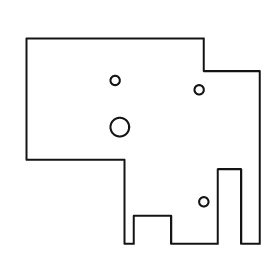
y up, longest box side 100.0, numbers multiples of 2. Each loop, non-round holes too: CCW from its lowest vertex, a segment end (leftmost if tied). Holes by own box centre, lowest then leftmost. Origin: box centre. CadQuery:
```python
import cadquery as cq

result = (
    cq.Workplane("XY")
    .moveTo(-8.0, -44.0)
    .lineTo(-4.0, -44.0)
    .lineTo(-4.0, -32.0)
    .lineTo(12.0, -32.0)
    .lineTo(12.0, -44.0)
    .lineTo(32.0, -44.0)
    .lineTo(32.0, -12.0)
    .lineTo(42.0, -12.0)
    .lineTo(42.0, -44.0)
    .lineTo(50.0, -44.0)
    .lineTo(50.0, 30.0)
    .lineTo(26.0, 30.0)
    .lineTo(26.0, 44.0)
    .lineTo(-50.0, 44.0)
    .lineTo(-50.0, -8.0)
    .lineTo(-8.0, -8.0)
    .close()
    .moveTo(26.0, -26.0)
    .circle(2.0)
    .moveTo(-10.0, 6.0)
    .circle(4.0)
    .moveTo(24.0, 22.0)
    .circle(2.0)
    .moveTo(-12.0, 26.0)
    .circle(2.0)
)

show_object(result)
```